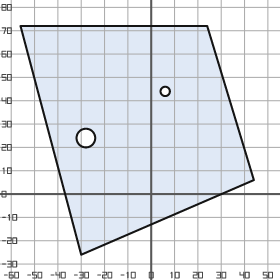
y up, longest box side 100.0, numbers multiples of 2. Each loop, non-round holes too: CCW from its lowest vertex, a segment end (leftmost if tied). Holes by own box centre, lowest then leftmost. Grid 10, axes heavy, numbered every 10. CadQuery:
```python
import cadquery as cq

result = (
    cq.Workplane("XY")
    .moveTo(-30.0, -26.0)
    .lineTo(44.0, 6.0)
    .lineTo(24.0, 72.0)
    .lineTo(-56.0, 72.0)
    .close()
    .moveTo(-28.0, 24.0)
    .circle(4.0)
    .moveTo(6.0, 44.0)
    .circle(2.0)
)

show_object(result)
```